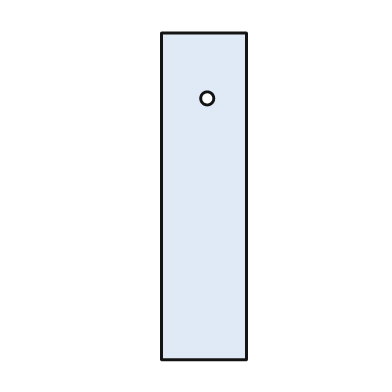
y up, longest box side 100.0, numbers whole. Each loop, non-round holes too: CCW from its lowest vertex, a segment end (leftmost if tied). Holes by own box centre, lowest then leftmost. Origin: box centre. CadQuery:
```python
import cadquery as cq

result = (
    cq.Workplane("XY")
    .moveTo(-13.0, -50.0)
    .lineTo(13.0, -50.0)
    .lineTo(13.0, 50.0)
    .lineTo(-13.0, 50.0)
    .close()
    .moveTo(1.0, 30.0)
    .circle(2.0)
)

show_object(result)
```